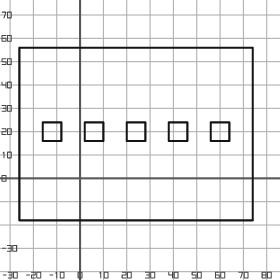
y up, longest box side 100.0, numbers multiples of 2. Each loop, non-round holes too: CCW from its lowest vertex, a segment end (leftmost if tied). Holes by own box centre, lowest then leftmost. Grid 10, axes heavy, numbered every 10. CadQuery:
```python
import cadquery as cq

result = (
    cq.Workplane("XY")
    .moveTo(-26.0, -18.0)
    .lineTo(74.0, -18.0)
    .lineTo(74.0, 56.0)
    .lineTo(-26.0, 56.0)
    .close()
    .moveTo(-16.0, 16.0)
    .lineTo(-8.0, 16.0)
    .lineTo(-8.0, 24.0)
    .lineTo(-16.0, 24.0)
    .close()
    .moveTo(2.0, 16.0)
    .lineTo(10.0, 16.0)
    .lineTo(10.0, 24.0)
    .lineTo(2.0, 24.0)
    .close()
    .moveTo(20.0, 16.0)
    .lineTo(28.0, 16.0)
    .lineTo(28.0, 24.0)
    .lineTo(20.0, 24.0)
    .close()
    .moveTo(38.0, 16.0)
    .lineTo(46.0, 16.0)
    .lineTo(46.0, 24.0)
    .lineTo(38.0, 24.0)
    .close()
    .moveTo(56.0, 16.0)
    .lineTo(64.0, 16.0)
    .lineTo(64.0, 24.0)
    .lineTo(56.0, 24.0)
    .close()
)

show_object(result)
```